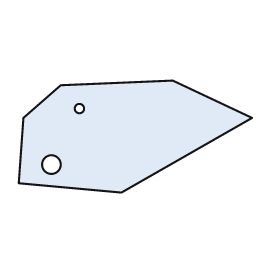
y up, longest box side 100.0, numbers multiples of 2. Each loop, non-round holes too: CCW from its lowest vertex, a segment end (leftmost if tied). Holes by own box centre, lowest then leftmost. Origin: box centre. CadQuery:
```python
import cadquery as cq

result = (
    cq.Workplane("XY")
    .moveTo(-6.0, -24.0)
    .lineTo(50.0, 8.0)
    .lineTo(16.0, 24.0)
    .lineTo(-32.0, 22.0)
    .lineTo(-48.0, 8.0)
    .lineTo(-50.0, -20.0)
    .close()
    .moveTo(-36.0, -12.0)
    .circle(4.0)
    .moveTo(-24.0, 12.0)
    .circle(2.0)
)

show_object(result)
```